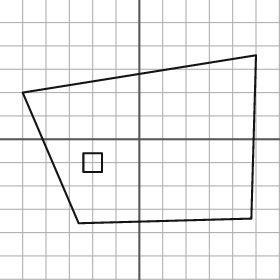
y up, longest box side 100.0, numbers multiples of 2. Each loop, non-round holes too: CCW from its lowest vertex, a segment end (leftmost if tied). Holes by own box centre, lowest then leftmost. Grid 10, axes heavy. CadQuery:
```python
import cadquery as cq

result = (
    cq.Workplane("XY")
    .moveTo(-26.0, -36.0)
    .lineTo(48.0, -34.0)
    .lineTo(50.0, 36.0)
    .lineTo(-50.0, 20.0)
    .close()
    .moveTo(-24.0, -14.0)
    .lineTo(-16.0, -14.0)
    .lineTo(-16.0, -6.0)
    .lineTo(-24.0, -6.0)
    .close()
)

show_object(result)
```